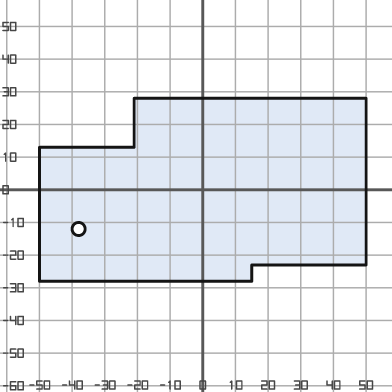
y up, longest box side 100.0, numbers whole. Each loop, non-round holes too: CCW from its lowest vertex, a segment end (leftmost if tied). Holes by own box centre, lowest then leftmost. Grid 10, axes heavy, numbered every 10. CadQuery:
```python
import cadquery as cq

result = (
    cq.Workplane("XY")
    .moveTo(-50.0, -28.0)
    .lineTo(15.0, -28.0)
    .lineTo(15.0, -23.0)
    .lineTo(50.0, -23.0)
    .lineTo(50.0, 28.0)
    .lineTo(-21.0, 28.0)
    .lineTo(-21.0, 13.0)
    .lineTo(-50.0, 13.0)
    .close()
    .moveTo(-38.0, -12.0)
    .circle(2.0)
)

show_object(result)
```